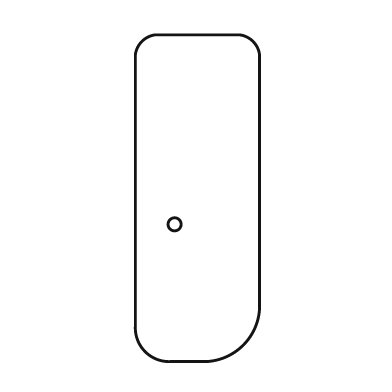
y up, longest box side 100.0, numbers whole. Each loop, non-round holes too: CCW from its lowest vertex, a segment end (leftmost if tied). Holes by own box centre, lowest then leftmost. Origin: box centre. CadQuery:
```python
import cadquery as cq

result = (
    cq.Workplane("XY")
    .moveTo(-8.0, -50.0)
    .lineTo(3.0, -50.0)
    .threePointArc((14.0, -45.0), (19.0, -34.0))
    .lineTo(19.0, 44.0)
    .threePointArc((17.0, 48.0), (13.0, 50.0))
    .lineTo(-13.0, 50.0)
    .threePointArc((-17.0, 48.0), (-19.0, 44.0))
    .lineTo(-19.0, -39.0)
    .threePointArc((-16.0, -47.0), (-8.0, -50.0))
    .close()
    .moveTo(-7.0, -8.0)
    .circle(2.0)
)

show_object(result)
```